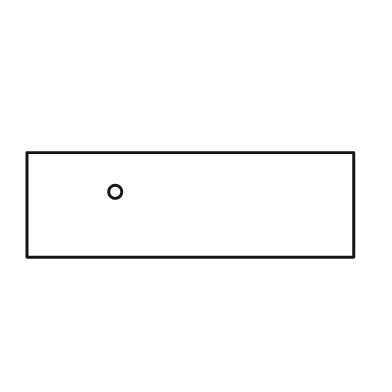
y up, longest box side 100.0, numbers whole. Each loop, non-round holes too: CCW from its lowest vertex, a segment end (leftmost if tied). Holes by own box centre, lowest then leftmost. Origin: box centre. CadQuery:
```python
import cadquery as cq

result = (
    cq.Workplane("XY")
    .moveTo(-50.0, -16.0)
    .lineTo(50.0, -16.0)
    .lineTo(50.0, 16.0)
    .lineTo(-50.0, 16.0)
    .close()
    .moveTo(-23.0, 4.0)
    .circle(2.0)
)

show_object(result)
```